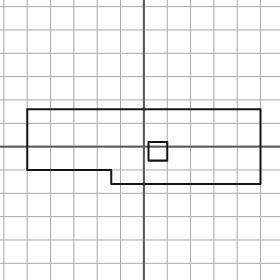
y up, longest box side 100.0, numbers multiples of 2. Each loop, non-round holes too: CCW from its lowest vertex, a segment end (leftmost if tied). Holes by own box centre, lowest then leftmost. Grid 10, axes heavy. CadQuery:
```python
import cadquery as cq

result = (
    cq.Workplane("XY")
    .moveTo(-14.0, -16.0)
    .lineTo(50.0, -16.0)
    .lineTo(50.0, 16.0)
    .lineTo(-50.0, 16.0)
    .lineTo(-50.0, -10.0)
    .lineTo(-14.0, -10.0)
    .close()
    .moveTo(2.0, -6.0)
    .lineTo(10.0, -6.0)
    .lineTo(10.0, 2.0)
    .lineTo(2.0, 2.0)
    .close()
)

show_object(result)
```